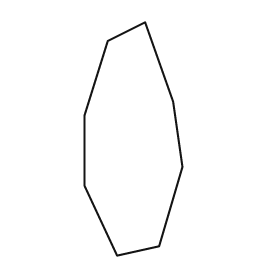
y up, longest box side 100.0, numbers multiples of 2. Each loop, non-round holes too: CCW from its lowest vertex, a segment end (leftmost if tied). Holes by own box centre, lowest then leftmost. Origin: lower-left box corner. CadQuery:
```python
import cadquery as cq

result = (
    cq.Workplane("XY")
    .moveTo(14.0, 0.0)
    .lineTo(32.0, 4.0)
    .lineTo(42.0, 38.0)
    .lineTo(38.0, 66.0)
    .lineTo(26.0, 100.0)
    .lineTo(10.0, 92.0)
    .lineTo(0.0, 60.0)
    .lineTo(0.0, 30.0)
    .close()
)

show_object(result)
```